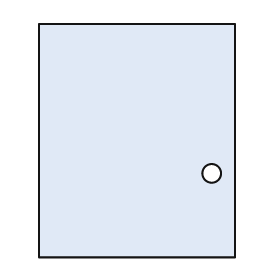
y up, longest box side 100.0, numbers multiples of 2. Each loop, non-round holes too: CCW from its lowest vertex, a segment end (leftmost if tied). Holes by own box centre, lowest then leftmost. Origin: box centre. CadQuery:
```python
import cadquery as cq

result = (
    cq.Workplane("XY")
    .moveTo(-42.0, -50.0)
    .lineTo(42.0, -50.0)
    .lineTo(42.0, 50.0)
    .lineTo(-42.0, 50.0)
    .close()
    .moveTo(32.0, -14.0)
    .circle(4.0)
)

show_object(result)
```